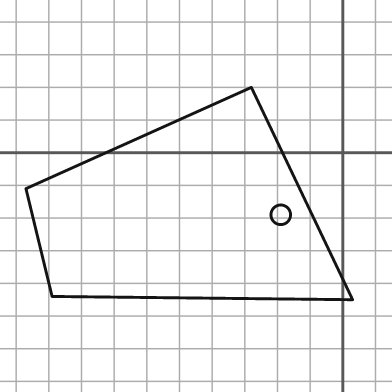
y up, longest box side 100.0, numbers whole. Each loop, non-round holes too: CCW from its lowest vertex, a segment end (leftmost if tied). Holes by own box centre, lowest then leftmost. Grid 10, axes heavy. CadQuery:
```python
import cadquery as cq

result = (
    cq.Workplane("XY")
    .moveTo(3.0, -45.0)
    .lineTo(-28.0, 20.0)
    .lineTo(-97.0, -11.0)
    .lineTo(-89.0, -44.0)
    .close()
    .moveTo(-19.0, -19.0)
    .circle(3.0)
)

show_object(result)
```